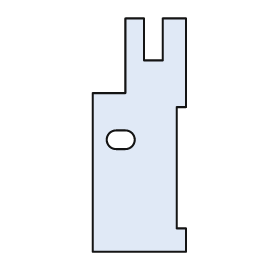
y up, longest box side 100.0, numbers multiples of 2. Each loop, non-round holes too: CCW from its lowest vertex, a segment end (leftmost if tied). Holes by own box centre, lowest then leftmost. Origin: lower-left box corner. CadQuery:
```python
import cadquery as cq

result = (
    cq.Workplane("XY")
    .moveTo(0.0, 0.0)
    .lineTo(40.0, 0.0)
    .lineTo(40.0, 10.0)
    .lineTo(36.0, 10.0)
    .lineTo(36.0, 62.0)
    .lineTo(40.0, 62.0)
    .lineTo(40.0, 100.0)
    .lineTo(30.0, 100.0)
    .lineTo(30.0, 82.0)
    .lineTo(22.0, 82.0)
    .lineTo(22.0, 100.0)
    .lineTo(14.0, 100.0)
    .lineTo(14.0, 68.0)
    .lineTo(0.0, 68.0)
    .close()
    .moveTo(10.0, 44.0)
    .lineTo(14.0, 44.0)
    .threePointArc((18.0, 48.0), (14.0, 52.0))
    .lineTo(10.0, 52.0)
    .threePointArc((6.0, 48.0), (10.0, 44.0))
    .close()
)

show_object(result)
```